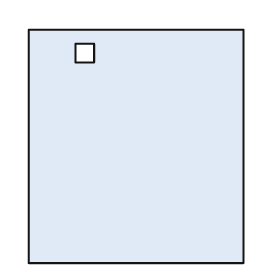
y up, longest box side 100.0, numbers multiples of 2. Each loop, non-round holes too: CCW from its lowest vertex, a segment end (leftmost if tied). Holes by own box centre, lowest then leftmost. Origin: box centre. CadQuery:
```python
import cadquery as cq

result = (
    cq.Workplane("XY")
    .moveTo(-46.0, -50.0)
    .lineTo(46.0, -50.0)
    .lineTo(46.0, 50.0)
    .lineTo(-46.0, 50.0)
    .close()
    .moveTo(-26.0, 36.0)
    .lineTo(-18.0, 36.0)
    .lineTo(-18.0, 44.0)
    .lineTo(-26.0, 44.0)
    .close()
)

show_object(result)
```